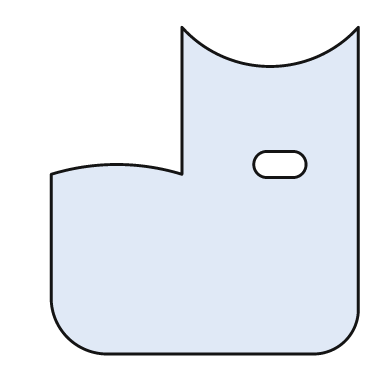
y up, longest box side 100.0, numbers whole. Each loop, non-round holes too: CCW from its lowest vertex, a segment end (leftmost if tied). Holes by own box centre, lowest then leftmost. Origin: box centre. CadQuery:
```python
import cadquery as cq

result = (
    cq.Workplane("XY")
    .moveTo(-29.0, -50.0)
    .lineTo(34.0, -50.0)
    .threePointArc((43.0, -46.0), (47.0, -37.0))
    .lineTo(47.0, 50.0)
    .threePointArc((20.0, 38.0), (-7.0, 50.0))
    .lineTo(-7.0, 5.0)
    .threePointArc((-27.0, 8.0), (-47.0, 5.0))
    .lineTo(-47.0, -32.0)
    .threePointArc((-42.0, -45.0), (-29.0, -50.0))
    .close()
    .moveTo(19.0, 4.0)
    .lineTo(27.0, 4.0)
    .threePointArc((31.0, 8.0), (27.0, 12.0))
    .lineTo(19.0, 12.0)
    .threePointArc((15.0, 8.0), (19.0, 4.0))
    .close()
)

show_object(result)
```